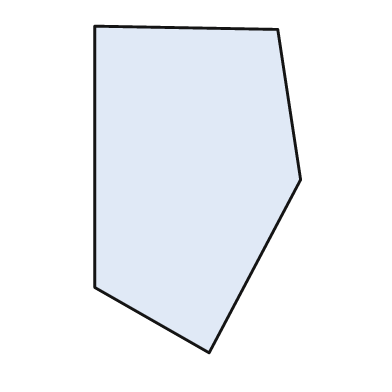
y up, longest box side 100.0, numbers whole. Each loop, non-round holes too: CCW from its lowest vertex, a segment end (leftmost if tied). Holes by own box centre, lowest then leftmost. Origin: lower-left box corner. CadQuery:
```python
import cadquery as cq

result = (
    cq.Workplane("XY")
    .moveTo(35.0, 0.0)
    .lineTo(63.0, 53.0)
    .lineTo(56.0, 99.0)
    .lineTo(0.0, 100.0)
    .lineTo(0.0, 20.0)
    .close()
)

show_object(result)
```